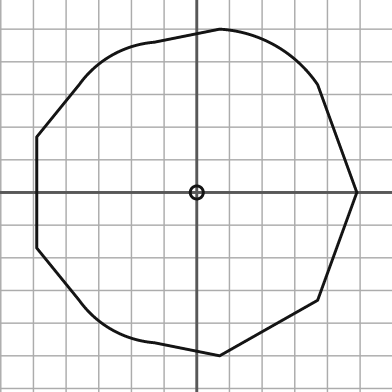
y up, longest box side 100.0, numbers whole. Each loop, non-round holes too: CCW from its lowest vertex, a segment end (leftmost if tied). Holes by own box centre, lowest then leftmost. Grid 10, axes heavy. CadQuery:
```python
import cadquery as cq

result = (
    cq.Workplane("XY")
    .moveTo(7.0, -50.0)
    .lineTo(37.0, -33.0)
    .lineTo(49.0, 0.0)
    .lineTo(37.0, 33.0)
    .threePointArc((24.0, 45.0), (7.0, 50.0))
    .lineTo(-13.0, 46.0)
    .threePointArc((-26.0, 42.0), (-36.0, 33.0))
    .lineTo(-49.0, 17.0)
    .lineTo(-49.0, -17.0)
    .lineTo(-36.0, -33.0)
    .threePointArc((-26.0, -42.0), (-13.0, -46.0))
    .close()
    .moveTo(0.0, 0.0)
    .circle(2.0)
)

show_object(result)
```